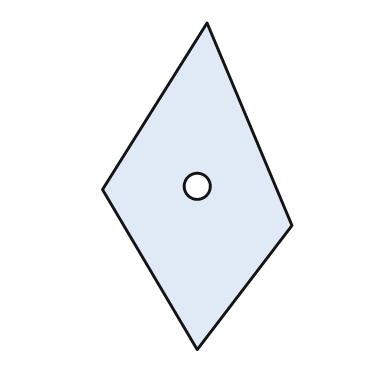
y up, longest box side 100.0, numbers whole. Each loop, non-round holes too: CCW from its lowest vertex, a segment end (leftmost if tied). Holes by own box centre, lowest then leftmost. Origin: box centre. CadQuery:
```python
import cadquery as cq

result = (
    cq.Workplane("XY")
    .moveTo(0.0, -50.0)
    .lineTo(29.0, -12.0)
    .lineTo(3.0, 50.0)
    .lineTo(-29.0, -1.0)
    .close()
    .moveTo(0.0, 0.0)
    .circle(4.0)
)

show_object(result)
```